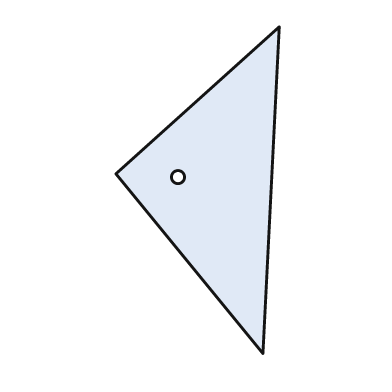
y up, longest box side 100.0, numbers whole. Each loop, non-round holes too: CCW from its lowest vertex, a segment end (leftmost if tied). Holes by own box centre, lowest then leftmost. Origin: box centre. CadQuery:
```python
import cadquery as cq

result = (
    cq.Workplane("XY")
    .moveTo(20.0, -50.0)
    .lineTo(25.0, 50.0)
    .lineTo(-25.0, 5.0)
    .close()
    .moveTo(-6.0, 4.0)
    .circle(2.0)
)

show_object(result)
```